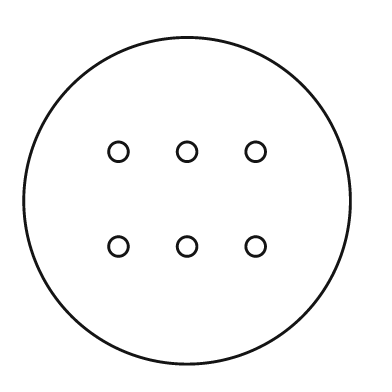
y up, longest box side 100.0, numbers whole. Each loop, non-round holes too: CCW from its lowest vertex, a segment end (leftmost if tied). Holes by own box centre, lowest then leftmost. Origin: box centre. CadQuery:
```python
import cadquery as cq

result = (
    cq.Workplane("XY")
    .moveTo(0.0, 0.0)
    .circle(50.0)
    .moveTo(-21.0, -14.0)
    .circle(3.0)
    .moveTo(0.0, -14.0)
    .circle(3.0)
    .moveTo(21.0, -14.0)
    .circle(3.0)
    .moveTo(-21.0, 15.0)
    .circle(3.0)
    .moveTo(0.0, 15.0)
    .circle(3.0)
    .moveTo(21.0, 15.0)
    .circle(3.0)
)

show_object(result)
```